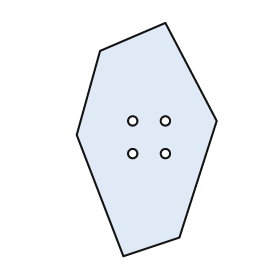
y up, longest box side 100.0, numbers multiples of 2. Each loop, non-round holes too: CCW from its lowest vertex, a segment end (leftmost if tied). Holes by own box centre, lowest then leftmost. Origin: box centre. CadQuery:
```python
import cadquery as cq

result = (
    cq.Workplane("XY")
    .moveTo(-10.0, -50.0)
    .lineTo(14.0, -42.0)
    .lineTo(30.0, 8.0)
    .lineTo(8.0, 50.0)
    .lineTo(-20.0, 38.0)
    .lineTo(-30.0, 2.0)
    .close()
    .moveTo(-6.0, -6.0)
    .circle(2.0)
    .moveTo(8.0, -6.0)
    .circle(2.0)
    .moveTo(-6.0, 8.0)
    .circle(2.0)
    .moveTo(8.0, 8.0)
    .circle(2.0)
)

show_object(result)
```